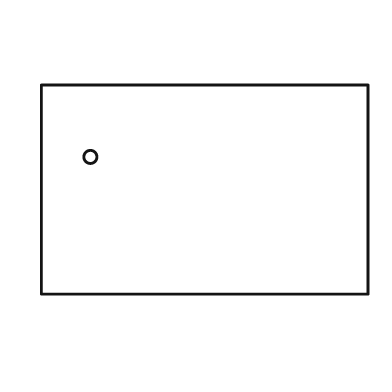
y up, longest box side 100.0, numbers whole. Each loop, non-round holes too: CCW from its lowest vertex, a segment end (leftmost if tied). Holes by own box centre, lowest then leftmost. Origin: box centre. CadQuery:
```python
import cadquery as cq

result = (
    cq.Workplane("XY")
    .moveTo(-50.0, -32.0)
    .lineTo(50.0, -32.0)
    .lineTo(50.0, 32.0)
    .lineTo(-50.0, 32.0)
    .close()
    .moveTo(-35.0, 10.0)
    .circle(2.0)
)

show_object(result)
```